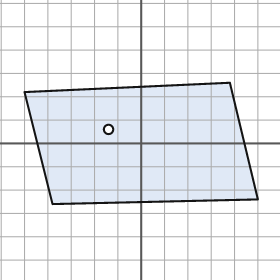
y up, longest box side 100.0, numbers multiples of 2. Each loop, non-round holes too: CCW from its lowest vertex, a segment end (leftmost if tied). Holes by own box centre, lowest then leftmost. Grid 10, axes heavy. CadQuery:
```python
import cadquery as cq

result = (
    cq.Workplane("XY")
    .moveTo(-38.0, -26.0)
    .lineTo(50.0, -24.0)
    .lineTo(38.0, 26.0)
    .lineTo(-50.0, 22.0)
    .close()
    .moveTo(-14.0, 6.0)
    .circle(2.0)
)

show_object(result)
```